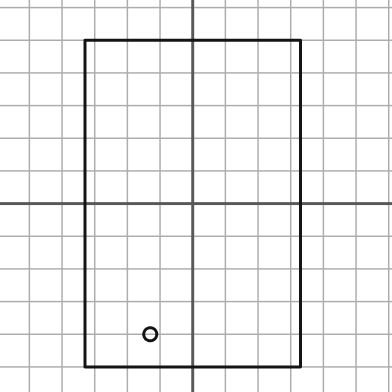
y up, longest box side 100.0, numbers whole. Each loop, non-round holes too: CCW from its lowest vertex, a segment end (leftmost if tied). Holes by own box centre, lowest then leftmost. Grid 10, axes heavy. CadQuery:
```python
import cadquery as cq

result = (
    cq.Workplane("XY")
    .moveTo(-33.0, -50.0)
    .lineTo(33.0, -50.0)
    .lineTo(33.0, 50.0)
    .lineTo(-33.0, 50.0)
    .close()
    .moveTo(-13.0, -40.0)
    .circle(2.0)
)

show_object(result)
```